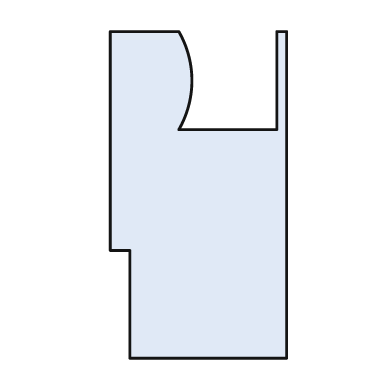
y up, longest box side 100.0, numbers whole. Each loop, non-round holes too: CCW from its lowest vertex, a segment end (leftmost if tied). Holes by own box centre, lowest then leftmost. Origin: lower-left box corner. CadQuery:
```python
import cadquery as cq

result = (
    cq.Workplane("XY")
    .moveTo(6.0, 0.0)
    .lineTo(54.0, 0.0)
    .lineTo(54.0, 100.0)
    .lineTo(51.0, 100.0)
    .lineTo(51.0, 70.0)
    .lineTo(21.0, 70.0)
    .threePointArc((25.0, 85.0), (21.0, 100.0))
    .lineTo(0.0, 100.0)
    .lineTo(0.0, 33.0)
    .lineTo(6.0, 33.0)
    .close()
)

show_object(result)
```